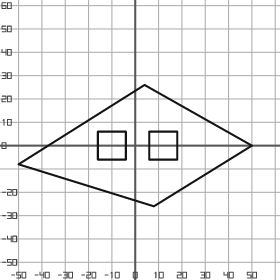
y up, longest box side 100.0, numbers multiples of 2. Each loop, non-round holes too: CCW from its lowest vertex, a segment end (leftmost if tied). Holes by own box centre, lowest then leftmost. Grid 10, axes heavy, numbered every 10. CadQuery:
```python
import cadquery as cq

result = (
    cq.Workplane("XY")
    .moveTo(8.0, -26.0)
    .lineTo(50.0, 0.0)
    .lineTo(4.0, 26.0)
    .lineTo(-50.0, -8.0)
    .close()
    .moveTo(-16.0, -6.0)
    .lineTo(-4.0, -6.0)
    .lineTo(-4.0, 6.0)
    .lineTo(-16.0, 6.0)
    .close()
    .moveTo(6.0, -6.0)
    .lineTo(18.0, -6.0)
    .lineTo(18.0, 6.0)
    .lineTo(6.0, 6.0)
    .close()
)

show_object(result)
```